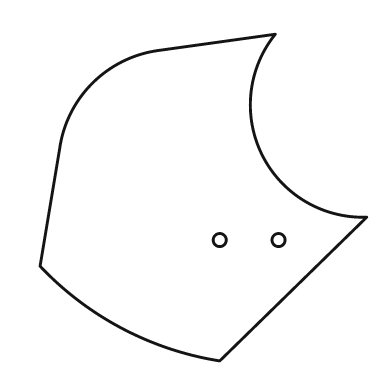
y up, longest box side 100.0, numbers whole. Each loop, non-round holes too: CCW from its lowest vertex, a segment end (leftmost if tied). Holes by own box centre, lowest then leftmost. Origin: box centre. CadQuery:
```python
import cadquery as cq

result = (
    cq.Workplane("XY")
    .moveTo(5.0, -50.0)
    .lineTo(50.0, -6.0)
    .threePointArc((18.0, 13.0), (22.0, 50.0))
    .lineTo(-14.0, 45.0)
    .threePointArc((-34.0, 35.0), (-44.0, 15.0))
    .lineTo(-50.0, -21.0)
    .threePointArc((-25.0, -40.0), (5.0, -50.0))
    .close()
    .moveTo(5.0, -13.0)
    .circle(2.0)
    .moveTo(23.0, -13.0)
    .circle(2.0)
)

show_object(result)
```